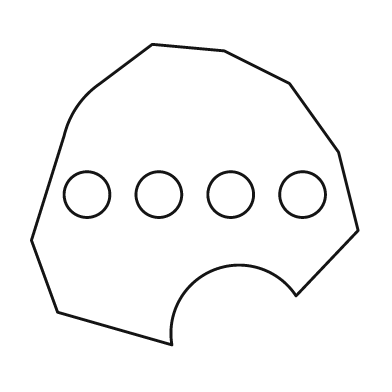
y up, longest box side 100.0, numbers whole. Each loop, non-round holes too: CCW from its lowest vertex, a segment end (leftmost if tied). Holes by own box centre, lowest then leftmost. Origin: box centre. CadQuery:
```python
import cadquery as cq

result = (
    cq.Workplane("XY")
    .moveTo(-7.0, -46.0)
    .threePointArc((6.0, -23.0), (31.0, -31.0))
    .lineTo(50.0, -11.0)
    .lineTo(44.0, 13.0)
    .lineTo(29.0, 34.0)
    .lineTo(9.0, 44.0)
    .lineTo(-13.0, 46.0)
    .lineTo(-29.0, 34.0)
    .threePointArc((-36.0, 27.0), (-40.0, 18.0))
    .lineTo(-50.0, -14.0)
    .lineTo(-42.0, -36.0)
    .close()
    .moveTo(-33.0, 0.0)
    .circle(7.0)
    .moveTo(-11.0, 0.0)
    .circle(7.0)
    .moveTo(11.0, 0.0)
    .circle(7.0)
    .moveTo(33.0, 0.0)
    .circle(7.0)
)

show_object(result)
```